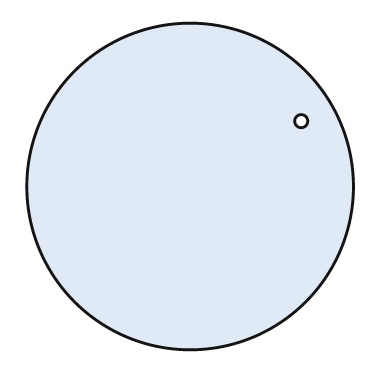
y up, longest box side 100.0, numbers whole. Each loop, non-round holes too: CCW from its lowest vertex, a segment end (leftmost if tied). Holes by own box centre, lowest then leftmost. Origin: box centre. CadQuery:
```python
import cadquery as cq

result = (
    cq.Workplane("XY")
    .moveTo(0.0, 0.0)
    .circle(50.0)
    .moveTo(34.0, 20.0)
    .circle(2.0)
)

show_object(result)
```